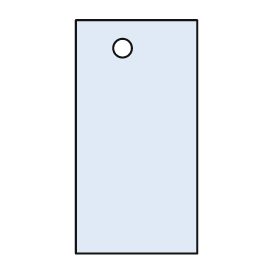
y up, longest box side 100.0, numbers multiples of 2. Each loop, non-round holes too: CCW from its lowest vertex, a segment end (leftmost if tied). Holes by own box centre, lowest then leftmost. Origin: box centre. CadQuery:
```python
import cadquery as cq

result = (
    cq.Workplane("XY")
    .moveTo(-26.0, -50.0)
    .lineTo(26.0, -50.0)
    .lineTo(26.0, 50.0)
    .lineTo(-26.0, 50.0)
    .close()
    .moveTo(-6.0, 38.0)
    .circle(4.0)
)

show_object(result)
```